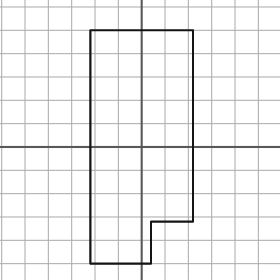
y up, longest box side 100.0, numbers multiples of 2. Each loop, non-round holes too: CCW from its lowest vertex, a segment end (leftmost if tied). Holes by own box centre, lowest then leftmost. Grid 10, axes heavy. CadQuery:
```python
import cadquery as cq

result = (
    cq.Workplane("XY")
    .moveTo(-22.0, -50.0)
    .lineTo(4.0, -50.0)
    .lineTo(4.0, -32.0)
    .lineTo(22.0, -32.0)
    .lineTo(22.0, 50.0)
    .lineTo(-22.0, 50.0)
    .close()
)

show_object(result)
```